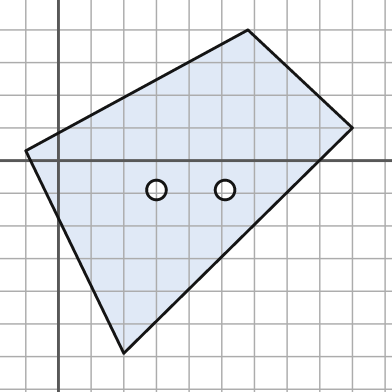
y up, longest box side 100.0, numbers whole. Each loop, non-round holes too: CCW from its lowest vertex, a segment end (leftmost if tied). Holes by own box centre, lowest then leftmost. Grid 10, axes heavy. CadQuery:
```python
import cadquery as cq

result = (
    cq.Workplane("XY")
    .moveTo(20.0, -59.0)
    .lineTo(90.0, 10.0)
    .lineTo(58.0, 40.0)
    .lineTo(-10.0, 3.0)
    .close()
    .moveTo(30.0, -9.0)
    .circle(3.0)
    .moveTo(51.0, -9.0)
    .circle(3.0)
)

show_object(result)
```